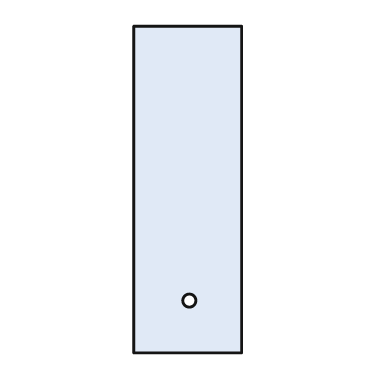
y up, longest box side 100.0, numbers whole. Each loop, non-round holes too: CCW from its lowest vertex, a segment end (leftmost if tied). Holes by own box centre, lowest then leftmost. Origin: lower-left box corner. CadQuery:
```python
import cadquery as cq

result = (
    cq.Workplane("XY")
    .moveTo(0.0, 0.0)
    .lineTo(33.0, 0.0)
    .lineTo(33.0, 100.0)
    .lineTo(0.0, 100.0)
    .close()
    .moveTo(17.0, 16.0)
    .circle(2.0)
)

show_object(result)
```